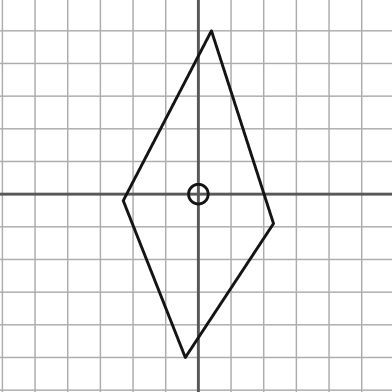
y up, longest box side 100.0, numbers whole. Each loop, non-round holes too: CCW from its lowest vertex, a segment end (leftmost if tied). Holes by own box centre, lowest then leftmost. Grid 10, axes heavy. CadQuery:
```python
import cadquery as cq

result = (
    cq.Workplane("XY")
    .moveTo(-4.0, -50.0)
    .lineTo(23.0, -9.0)
    .lineTo(4.0, 50.0)
    .lineTo(-23.0, -2.0)
    .close()
    .moveTo(0.0, 0.0)
    .circle(3.0)
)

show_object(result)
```